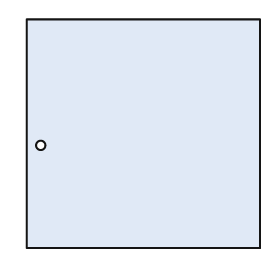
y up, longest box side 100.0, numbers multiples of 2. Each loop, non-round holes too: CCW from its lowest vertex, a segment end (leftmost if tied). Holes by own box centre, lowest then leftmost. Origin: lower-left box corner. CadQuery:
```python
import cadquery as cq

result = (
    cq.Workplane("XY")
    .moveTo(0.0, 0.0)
    .lineTo(100.0, 0.0)
    .lineTo(100.0, 98.0)
    .lineTo(0.0, 98.0)
    .close()
    .moveTo(6.0, 44.0)
    .circle(2.0)
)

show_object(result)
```